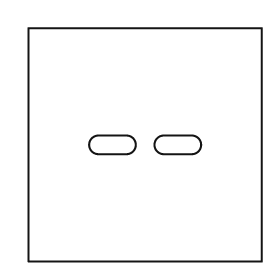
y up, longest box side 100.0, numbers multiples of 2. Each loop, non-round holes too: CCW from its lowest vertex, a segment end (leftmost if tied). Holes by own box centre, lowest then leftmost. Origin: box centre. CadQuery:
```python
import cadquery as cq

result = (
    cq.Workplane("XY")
    .moveTo(-50.0, -50.0)
    .lineTo(50.0, -50.0)
    .lineTo(50.0, 50.0)
    .lineTo(-50.0, 50.0)
    .close()
    .moveTo(-20.0, -4.0)
    .lineTo(-8.0, -4.0)
    .threePointArc((-4.0, 0.0), (-8.0, 4.0))
    .lineTo(-20.0, 4.0)
    .threePointArc((-24.0, 0.0), (-20.0, -4.0))
    .close()
    .moveTo(8.0, -4.0)
    .lineTo(20.0, -4.0)
    .threePointArc((24.0, 0.0), (20.0, 4.0))
    .lineTo(8.0, 4.0)
    .threePointArc((4.0, 0.0), (8.0, -4.0))
    .close()
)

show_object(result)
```